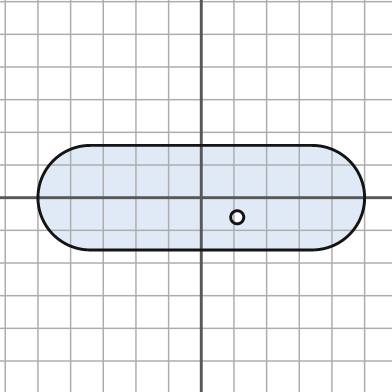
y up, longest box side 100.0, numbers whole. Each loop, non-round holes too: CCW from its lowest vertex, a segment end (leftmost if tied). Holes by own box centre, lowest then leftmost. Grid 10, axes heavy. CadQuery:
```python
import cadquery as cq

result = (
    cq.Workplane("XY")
    .moveTo(-34.0, -16.0)
    .lineTo(34.0, -16.0)
    .threePointArc((50.0, 0.0), (34.0, 16.0))
    .lineTo(-34.0, 16.0)
    .threePointArc((-50.0, 0.0), (-34.0, -16.0))
    .close()
    .moveTo(11.0, -6.0)
    .circle(2.0)
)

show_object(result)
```